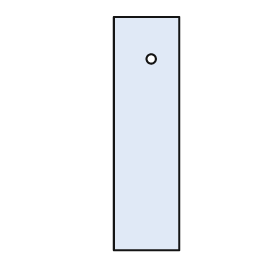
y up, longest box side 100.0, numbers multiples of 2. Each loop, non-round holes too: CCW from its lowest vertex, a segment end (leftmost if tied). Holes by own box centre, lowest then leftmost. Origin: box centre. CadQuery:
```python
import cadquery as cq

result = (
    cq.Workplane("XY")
    .moveTo(-14.0, -50.0)
    .lineTo(14.0, -50.0)
    .lineTo(14.0, 50.0)
    .lineTo(-14.0, 50.0)
    .close()
    .moveTo(2.0, 32.0)
    .circle(2.0)
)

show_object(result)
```